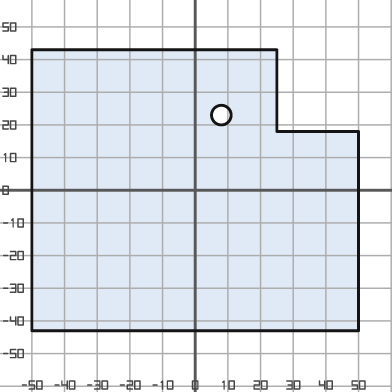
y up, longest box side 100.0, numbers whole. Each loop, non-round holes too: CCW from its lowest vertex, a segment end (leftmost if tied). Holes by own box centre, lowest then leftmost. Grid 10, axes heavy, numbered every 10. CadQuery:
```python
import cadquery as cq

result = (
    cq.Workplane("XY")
    .moveTo(-50.0, -43.0)
    .lineTo(50.0, -43.0)
    .lineTo(50.0, 18.0)
    .lineTo(25.0, 18.0)
    .lineTo(25.0, 43.0)
    .lineTo(-50.0, 43.0)
    .close()
    .moveTo(8.0, 23.0)
    .circle(3.0)
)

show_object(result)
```